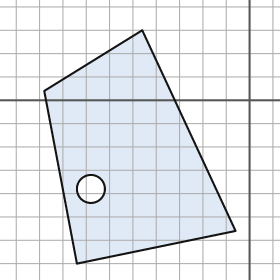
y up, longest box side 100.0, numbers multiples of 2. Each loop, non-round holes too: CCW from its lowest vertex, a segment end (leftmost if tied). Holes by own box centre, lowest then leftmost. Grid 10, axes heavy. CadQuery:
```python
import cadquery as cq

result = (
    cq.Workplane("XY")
    .moveTo(-74.0, -70.0)
    .lineTo(-6.0, -56.0)
    .lineTo(-46.0, 30.0)
    .lineTo(-88.0, 4.0)
    .close()
    .moveTo(-68.0, -38.0)
    .circle(6.0)
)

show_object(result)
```